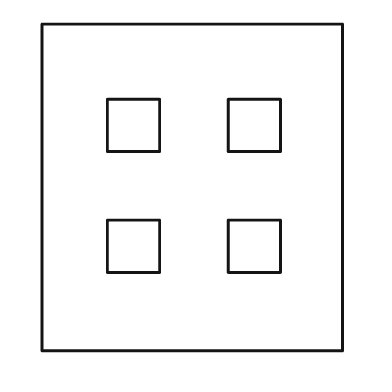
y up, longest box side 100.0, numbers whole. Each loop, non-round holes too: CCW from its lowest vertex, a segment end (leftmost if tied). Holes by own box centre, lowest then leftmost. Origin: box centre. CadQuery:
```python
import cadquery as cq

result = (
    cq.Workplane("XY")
    .moveTo(-46.0, -50.0)
    .lineTo(46.0, -50.0)
    .lineTo(46.0, 50.0)
    .lineTo(-46.0, 50.0)
    .close()
    .moveTo(-26.0, -26.0)
    .lineTo(-10.0, -26.0)
    .lineTo(-10.0, -10.0)
    .lineTo(-26.0, -10.0)
    .close()
    .moveTo(11.0, -26.0)
    .lineTo(27.0, -26.0)
    .lineTo(27.0, -10.0)
    .lineTo(11.0, -10.0)
    .close()
    .moveTo(-26.0, 11.0)
    .lineTo(-10.0, 11.0)
    .lineTo(-10.0, 27.0)
    .lineTo(-26.0, 27.0)
    .close()
    .moveTo(11.0, 11.0)
    .lineTo(27.0, 11.0)
    .lineTo(27.0, 27.0)
    .lineTo(11.0, 27.0)
    .close()
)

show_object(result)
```